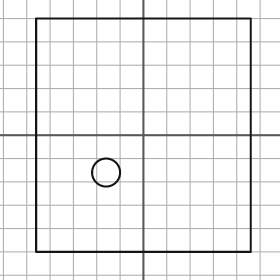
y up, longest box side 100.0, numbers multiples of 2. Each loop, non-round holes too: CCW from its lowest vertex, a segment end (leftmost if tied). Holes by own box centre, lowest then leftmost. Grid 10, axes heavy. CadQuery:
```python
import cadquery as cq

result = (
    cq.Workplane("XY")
    .moveTo(-46.0, -50.0)
    .lineTo(46.0, -50.0)
    .lineTo(46.0, 50.0)
    .lineTo(-46.0, 50.0)
    .close()
    .moveTo(-16.0, -16.0)
    .circle(6.0)
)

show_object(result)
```